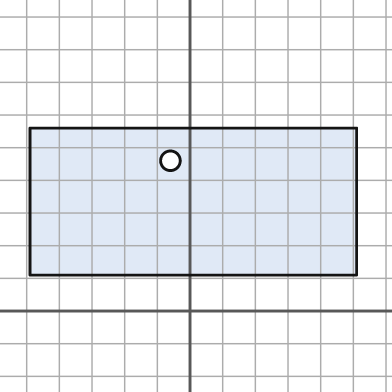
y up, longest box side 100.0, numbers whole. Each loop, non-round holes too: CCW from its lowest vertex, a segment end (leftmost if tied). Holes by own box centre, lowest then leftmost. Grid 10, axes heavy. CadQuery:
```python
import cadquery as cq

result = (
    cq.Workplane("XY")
    .moveTo(-49.0, 11.0)
    .lineTo(51.0, 11.0)
    .lineTo(51.0, 56.0)
    .lineTo(-49.0, 56.0)
    .close()
    .moveTo(-6.0, 46.0)
    .circle(3.0)
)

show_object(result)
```